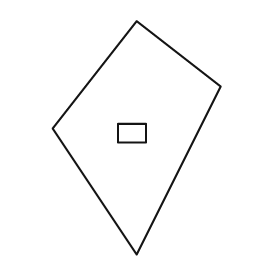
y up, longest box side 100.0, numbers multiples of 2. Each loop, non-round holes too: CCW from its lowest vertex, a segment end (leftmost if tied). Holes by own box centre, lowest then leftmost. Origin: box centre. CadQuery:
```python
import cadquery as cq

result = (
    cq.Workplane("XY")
    .moveTo(0.0, -50.0)
    .lineTo(36.0, 22.0)
    .lineTo(0.0, 50.0)
    .lineTo(-36.0, 4.0)
    .close()
    .moveTo(-8.0, -2.0)
    .lineTo(4.0, -2.0)
    .lineTo(4.0, 6.0)
    .lineTo(-8.0, 6.0)
    .close()
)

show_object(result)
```